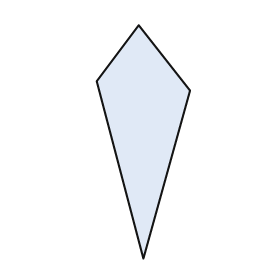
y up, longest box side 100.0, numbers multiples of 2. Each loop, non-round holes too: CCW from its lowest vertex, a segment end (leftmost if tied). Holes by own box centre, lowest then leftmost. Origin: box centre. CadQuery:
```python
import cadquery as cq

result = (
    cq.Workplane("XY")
    .moveTo(0.0, -50.0)
    .lineTo(20.0, 22.0)
    .lineTo(-2.0, 50.0)
    .lineTo(-20.0, 26.0)
    .close()
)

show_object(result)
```